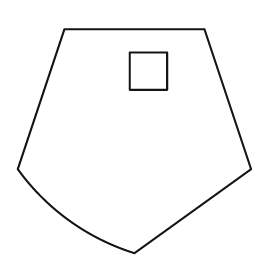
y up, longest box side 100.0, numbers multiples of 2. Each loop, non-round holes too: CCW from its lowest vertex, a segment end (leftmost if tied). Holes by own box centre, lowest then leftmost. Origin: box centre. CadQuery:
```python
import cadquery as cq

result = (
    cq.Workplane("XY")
    .moveTo(0.0, -48.0)
    .lineTo(50.0, -12.0)
    .lineTo(30.0, 48.0)
    .lineTo(-30.0, 48.0)
    .lineTo(-50.0, -12.0)
    .threePointArc((-28.0, -34.0), (0.0, -48.0))
    .close()
    .moveTo(-2.0, 22.0)
    .lineTo(14.0, 22.0)
    .lineTo(14.0, 38.0)
    .lineTo(-2.0, 38.0)
    .close()
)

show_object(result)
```